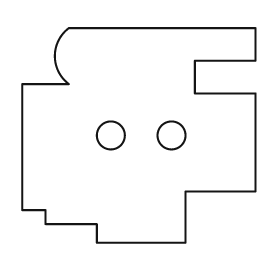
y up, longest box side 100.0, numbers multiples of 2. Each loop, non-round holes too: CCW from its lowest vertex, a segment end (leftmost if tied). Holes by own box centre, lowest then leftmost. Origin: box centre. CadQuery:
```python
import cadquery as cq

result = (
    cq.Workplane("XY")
    .moveTo(-18.0, -46.0)
    .lineTo(20.0, -46.0)
    .lineTo(20.0, -24.0)
    .lineTo(50.0, -24.0)
    .lineTo(50.0, 18.0)
    .lineTo(24.0, 18.0)
    .lineTo(24.0, 32.0)
    .lineTo(50.0, 32.0)
    .lineTo(50.0, 46.0)
    .lineTo(-30.0, 46.0)
    .threePointArc((-36.0, 34.0), (-30.0, 22.0))
    .lineTo(-50.0, 22.0)
    .lineTo(-50.0, -32.0)
    .lineTo(-40.0, -32.0)
    .lineTo(-40.0, -38.0)
    .lineTo(-18.0, -38.0)
    .close()
    .moveTo(-12.0, 0.0)
    .circle(6.0)
    .moveTo(14.0, 0.0)
    .circle(6.0)
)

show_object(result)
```